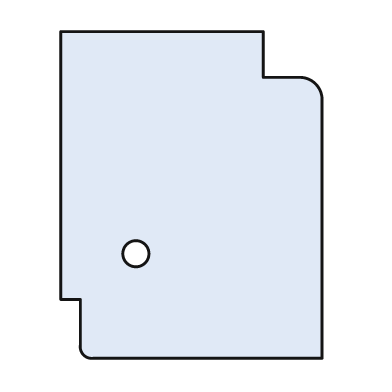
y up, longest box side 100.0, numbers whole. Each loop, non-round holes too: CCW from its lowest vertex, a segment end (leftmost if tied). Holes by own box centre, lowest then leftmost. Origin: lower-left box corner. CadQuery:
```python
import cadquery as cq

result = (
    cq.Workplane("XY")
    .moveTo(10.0, 0.0)
    .lineTo(80.0, 0.0)
    .lineTo(80.0, 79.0)
    .threePointArc((78.0, 84.0), (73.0, 86.0))
    .lineTo(62.0, 86.0)
    .lineTo(62.0, 100.0)
    .lineTo(0.0, 100.0)
    .lineTo(0.0, 18.0)
    .lineTo(6.0, 18.0)
    .lineTo(6.0, 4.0)
    .threePointArc((7.0, 1.0), (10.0, 0.0))
    .close()
    .moveTo(23.0, 32.0)
    .circle(4.0)
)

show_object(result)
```